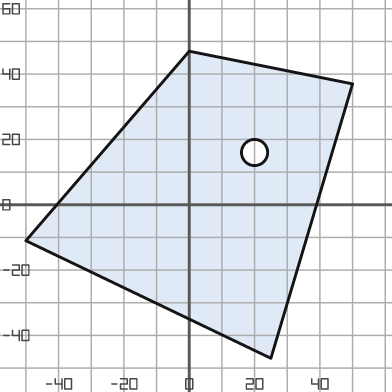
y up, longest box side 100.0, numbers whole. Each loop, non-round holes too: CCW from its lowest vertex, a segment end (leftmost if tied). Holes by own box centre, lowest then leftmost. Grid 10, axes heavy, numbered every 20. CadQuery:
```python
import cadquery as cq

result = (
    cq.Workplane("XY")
    .moveTo(25.0, -47.0)
    .lineTo(50.0, 37.0)
    .lineTo(0.0, 47.0)
    .lineTo(-50.0, -11.0)
    .close()
    .moveTo(20.0, 16.0)
    .circle(4.0)
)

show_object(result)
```